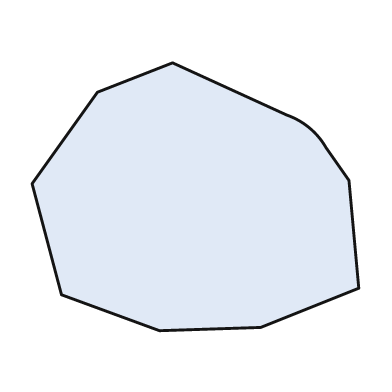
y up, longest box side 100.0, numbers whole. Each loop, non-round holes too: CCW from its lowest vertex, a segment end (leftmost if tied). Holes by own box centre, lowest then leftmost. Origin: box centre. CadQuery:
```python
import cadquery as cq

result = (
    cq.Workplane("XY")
    .moveTo(-11.0, -41.0)
    .lineTo(20.0, -40.0)
    .lineTo(50.0, -28.0)
    .lineTo(47.0, 5.0)
    .lineTo(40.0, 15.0)
    .threePointArc((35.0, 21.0), (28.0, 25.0))
    .lineTo(-7.0, 41.0)
    .lineTo(-30.0, 32.0)
    .lineTo(-50.0, 4.0)
    .lineTo(-41.0, -30.0)
    .close()
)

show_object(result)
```